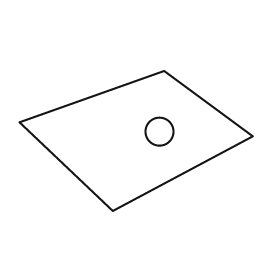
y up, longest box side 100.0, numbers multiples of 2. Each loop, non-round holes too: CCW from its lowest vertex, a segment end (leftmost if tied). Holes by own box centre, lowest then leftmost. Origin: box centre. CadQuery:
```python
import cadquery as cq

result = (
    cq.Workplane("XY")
    .moveTo(-10.0, -30.0)
    .lineTo(50.0, 2.0)
    .lineTo(12.0, 30.0)
    .lineTo(-50.0, 8.0)
    .close()
    .moveTo(10.0, 4.0)
    .circle(6.0)
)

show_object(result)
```